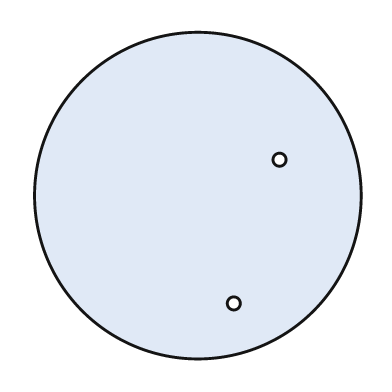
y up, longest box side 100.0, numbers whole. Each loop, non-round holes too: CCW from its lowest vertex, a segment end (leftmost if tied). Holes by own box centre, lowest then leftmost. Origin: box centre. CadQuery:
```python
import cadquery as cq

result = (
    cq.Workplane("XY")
    .moveTo(0.0, 0.0)
    .circle(50.0)
    .moveTo(11.0, -33.0)
    .circle(2.0)
    .moveTo(25.0, 11.0)
    .circle(2.0)
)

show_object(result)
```